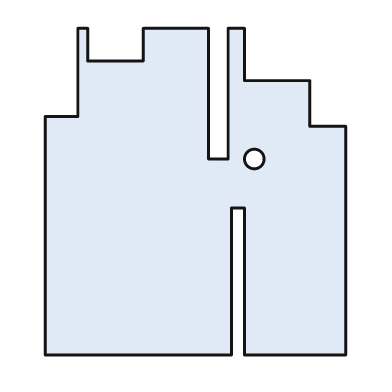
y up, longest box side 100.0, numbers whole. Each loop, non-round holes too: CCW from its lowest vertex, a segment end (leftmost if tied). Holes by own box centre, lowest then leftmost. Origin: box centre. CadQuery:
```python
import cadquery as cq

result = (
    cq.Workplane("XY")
    .moveTo(-46.0, -50.0)
    .lineTo(11.0, -50.0)
    .lineTo(11.0, -5.0)
    .lineTo(15.0, -5.0)
    .lineTo(15.0, -50.0)
    .lineTo(46.0, -50.0)
    .lineTo(46.0, 20.0)
    .lineTo(35.0, 20.0)
    .lineTo(35.0, 34.0)
    .lineTo(15.0, 34.0)
    .lineTo(15.0, 50.0)
    .lineTo(10.0, 50.0)
    .lineTo(10.0, 10.0)
    .lineTo(4.0, 10.0)
    .lineTo(4.0, 50.0)
    .lineTo(-16.0, 50.0)
    .lineTo(-16.0, 40.0)
    .lineTo(-33.0, 40.0)
    .lineTo(-33.0, 50.0)
    .lineTo(-36.0, 50.0)
    .lineTo(-36.0, 23.0)
    .lineTo(-46.0, 23.0)
    .close()
    .moveTo(18.0, 10.0)
    .circle(3.0)
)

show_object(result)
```